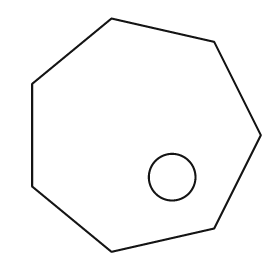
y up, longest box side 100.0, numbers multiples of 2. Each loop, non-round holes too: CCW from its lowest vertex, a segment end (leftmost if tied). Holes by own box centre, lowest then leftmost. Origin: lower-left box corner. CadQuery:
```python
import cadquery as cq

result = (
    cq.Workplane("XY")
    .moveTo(34.0, 0.0)
    .lineTo(78.0, 10.0)
    .lineTo(98.0, 50.0)
    .lineTo(78.0, 90.0)
    .lineTo(34.0, 100.0)
    .lineTo(0.0, 72.0)
    .lineTo(0.0, 28.0)
    .close()
    .moveTo(60.0, 32.0)
    .circle(10.0)
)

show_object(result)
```